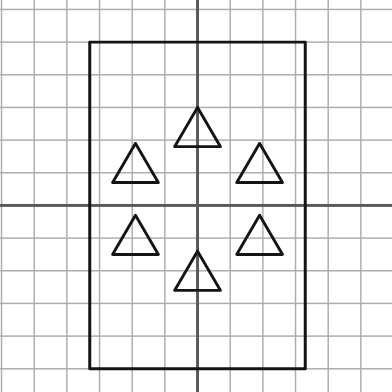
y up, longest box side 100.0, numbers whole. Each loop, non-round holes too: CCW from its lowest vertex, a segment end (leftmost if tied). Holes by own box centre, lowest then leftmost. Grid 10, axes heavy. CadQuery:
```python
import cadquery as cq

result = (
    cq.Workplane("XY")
    .moveTo(-33.0, -50.0)
    .lineTo(33.0, -50.0)
    .lineTo(33.0, 50.0)
    .lineTo(-33.0, 50.0)
    .close()
    .moveTo(-7.0, -26.0)
    .lineTo(7.0, -26.0)
    .lineTo(0.0, -14.0)
    .close()
    .moveTo(-26.0, -15.0)
    .lineTo(-12.0, -15.0)
    .lineTo(-19.0, -3.0)
    .close()
    .moveTo(12.0, -15.0)
    .lineTo(26.0, -15.0)
    .lineTo(19.0, -3.0)
    .close()
    .moveTo(-26.0, 7.0)
    .lineTo(-12.0, 7.0)
    .lineTo(-19.0, 19.0)
    .close()
    .moveTo(12.0, 7.0)
    .lineTo(26.0, 7.0)
    .lineTo(19.0, 19.0)
    .close()
    .moveTo(-7.0, 18.0)
    .lineTo(7.0, 18.0)
    .lineTo(0.0, 30.0)
    .close()
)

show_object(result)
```